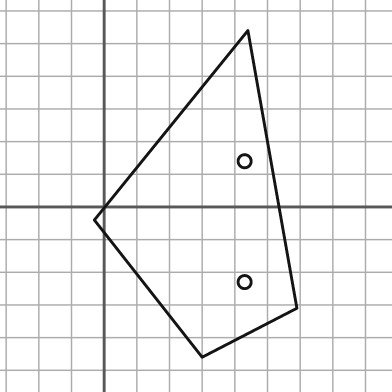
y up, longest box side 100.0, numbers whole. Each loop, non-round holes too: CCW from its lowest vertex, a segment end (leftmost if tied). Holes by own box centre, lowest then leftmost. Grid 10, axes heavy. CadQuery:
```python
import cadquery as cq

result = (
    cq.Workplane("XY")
    .moveTo(30.0, -46.0)
    .lineTo(59.0, -31.0)
    .lineTo(44.0, 54.0)
    .lineTo(-3.0, -4.0)
    .close()
    .moveTo(43.0, -23.0)
    .circle(2.0)
    .moveTo(43.0, 14.0)
    .circle(2.0)
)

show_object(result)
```